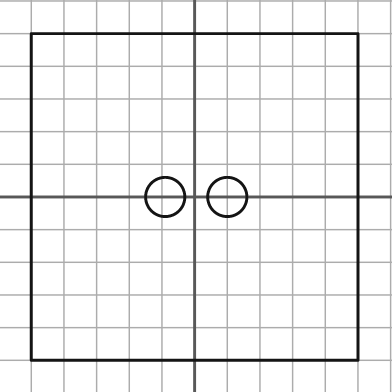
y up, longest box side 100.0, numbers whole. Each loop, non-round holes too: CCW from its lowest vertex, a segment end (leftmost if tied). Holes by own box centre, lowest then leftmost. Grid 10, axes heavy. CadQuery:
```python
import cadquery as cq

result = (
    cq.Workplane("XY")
    .moveTo(-50.0, -50.0)
    .lineTo(50.0, -50.0)
    .lineTo(50.0, 50.0)
    .lineTo(-50.0, 50.0)
    .close()
    .moveTo(-9.0, 0.0)
    .circle(6.0)
    .moveTo(10.0, 0.0)
    .circle(6.0)
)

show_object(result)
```